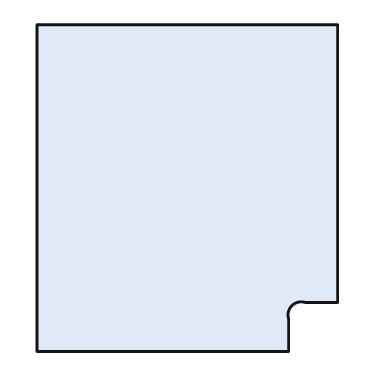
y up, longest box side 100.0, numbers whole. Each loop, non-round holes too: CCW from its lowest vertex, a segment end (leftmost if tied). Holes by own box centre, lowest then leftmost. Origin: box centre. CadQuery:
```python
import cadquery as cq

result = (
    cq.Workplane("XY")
    .moveTo(-46.0, -50.0)
    .lineTo(31.0, -50.0)
    .lineTo(31.0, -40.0)
    .threePointArc((32.0, -36.0), (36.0, -35.0))
    .lineTo(46.0, -35.0)
    .lineTo(46.0, 50.0)
    .lineTo(-46.0, 50.0)
    .close()
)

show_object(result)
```